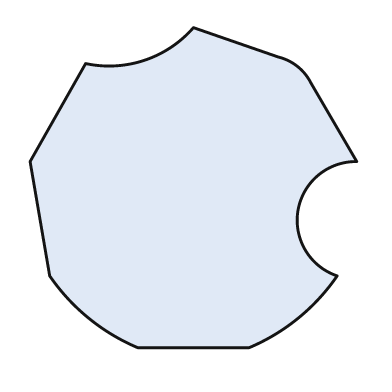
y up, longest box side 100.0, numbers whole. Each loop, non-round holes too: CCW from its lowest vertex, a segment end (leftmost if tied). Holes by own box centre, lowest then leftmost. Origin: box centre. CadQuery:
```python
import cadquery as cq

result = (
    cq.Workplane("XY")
    .moveTo(-17.0, -49.0)
    .lineTo(17.0, -49.0)
    .threePointArc((32.0, -40.0), (44.0, -27.0))
    .threePointArc((32.0, -7.0), (50.0, 8.0))
    .lineTo(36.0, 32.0)
    .threePointArc((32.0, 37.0), (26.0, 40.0))
    .lineTo(0.0, 49.0)
    .threePointArc((-15.0, 39.0), (-33.0, 38.0))
    .lineTo(-50.0, 8.0)
    .lineTo(-44.0, -27.0)
    .threePointArc((-32.0, -40.0), (-17.0, -49.0))
    .close()
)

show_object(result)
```